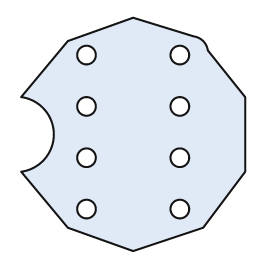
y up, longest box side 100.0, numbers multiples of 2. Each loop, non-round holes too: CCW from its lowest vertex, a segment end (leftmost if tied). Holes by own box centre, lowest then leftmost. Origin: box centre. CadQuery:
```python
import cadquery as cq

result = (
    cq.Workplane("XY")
    .moveTo(0.0, -50.0)
    .lineTo(30.0, -40.0)
    .lineTo(48.0, -16.0)
    .lineTo(48.0, 16.0)
    .lineTo(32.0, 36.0)
    .threePointArc((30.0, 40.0), (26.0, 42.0))
    .lineTo(0.0, 50.0)
    .lineTo(-28.0, 40.0)
    .lineTo(-48.0, 16.0)
    .threePointArc((-34.0, 0.0), (-48.0, -16.0))
    .lineTo(-28.0, -40.0)
    .close()
    .moveTo(-20.0, -32.0)
    .circle(4.0)
    .moveTo(20.0, -32.0)
    .circle(4.0)
    .moveTo(-20.0, -10.0)
    .circle(4.0)
    .moveTo(20.0, -10.0)
    .circle(4.0)
    .moveTo(-20.0, 12.0)
    .circle(4.0)
    .moveTo(20.0, 12.0)
    .circle(4.0)
    .moveTo(-20.0, 34.0)
    .circle(4.0)
    .moveTo(20.0, 34.0)
    .circle(4.0)
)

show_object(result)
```